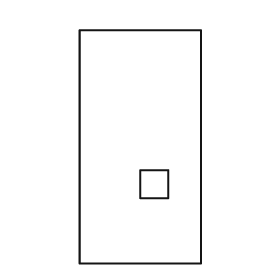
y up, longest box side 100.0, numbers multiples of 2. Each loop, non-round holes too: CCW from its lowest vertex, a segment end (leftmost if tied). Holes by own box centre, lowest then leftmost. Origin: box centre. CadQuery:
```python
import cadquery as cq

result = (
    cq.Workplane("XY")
    .moveTo(-26.0, -50.0)
    .lineTo(26.0, -50.0)
    .lineTo(26.0, 50.0)
    .lineTo(-26.0, 50.0)
    .close()
    .moveTo(0.0, -22.0)
    .lineTo(12.0, -22.0)
    .lineTo(12.0, -10.0)
    .lineTo(0.0, -10.0)
    .close()
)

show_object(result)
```